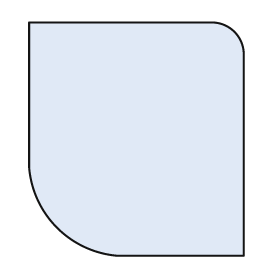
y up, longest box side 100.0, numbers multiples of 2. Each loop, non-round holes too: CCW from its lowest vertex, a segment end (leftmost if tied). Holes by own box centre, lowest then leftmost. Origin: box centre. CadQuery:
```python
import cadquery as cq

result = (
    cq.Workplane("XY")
    .moveTo(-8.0, -50.0)
    .lineTo(46.0, -50.0)
    .lineTo(46.0, 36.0)
    .threePointArc((42.0, 46.0), (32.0, 50.0))
    .lineTo(-46.0, 50.0)
    .lineTo(-46.0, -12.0)
    .threePointArc((-34.0, -38.0), (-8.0, -50.0))
    .close()
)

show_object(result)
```